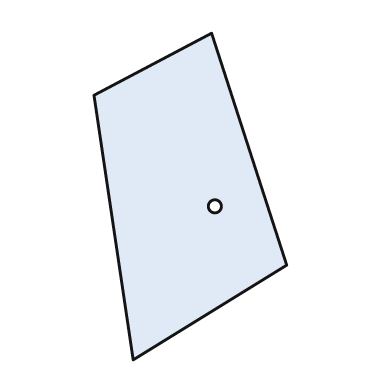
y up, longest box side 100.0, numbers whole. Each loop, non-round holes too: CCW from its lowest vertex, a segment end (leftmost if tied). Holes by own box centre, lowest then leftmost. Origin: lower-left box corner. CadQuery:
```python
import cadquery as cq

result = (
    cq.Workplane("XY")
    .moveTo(12.0, 0.0)
    .lineTo(59.0, 29.0)
    .lineTo(36.0, 100.0)
    .lineTo(0.0, 81.0)
    .close()
    .moveTo(37.0, 47.0)
    .circle(2.0)
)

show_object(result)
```